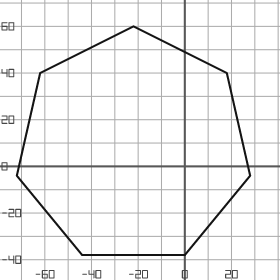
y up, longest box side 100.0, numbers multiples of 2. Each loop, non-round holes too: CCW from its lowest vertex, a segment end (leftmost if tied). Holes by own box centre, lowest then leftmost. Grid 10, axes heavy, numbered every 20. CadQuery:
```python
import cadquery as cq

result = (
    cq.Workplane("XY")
    .moveTo(-44.0, -38.0)
    .lineTo(0.0, -38.0)
    .lineTo(28.0, -4.0)
    .lineTo(18.0, 40.0)
    .lineTo(-22.0, 60.0)
    .lineTo(-62.0, 40.0)
    .lineTo(-72.0, -4.0)
    .close()
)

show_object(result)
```